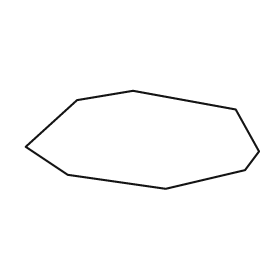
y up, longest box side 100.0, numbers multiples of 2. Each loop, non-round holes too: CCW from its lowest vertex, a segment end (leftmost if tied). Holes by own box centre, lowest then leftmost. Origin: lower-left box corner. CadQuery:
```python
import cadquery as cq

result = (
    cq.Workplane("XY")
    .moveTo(60.0, 0.0)
    .lineTo(94.0, 8.0)
    .lineTo(100.0, 16.0)
    .lineTo(90.0, 34.0)
    .lineTo(46.0, 42.0)
    .lineTo(22.0, 38.0)
    .lineTo(0.0, 18.0)
    .lineTo(18.0, 6.0)
    .close()
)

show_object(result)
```